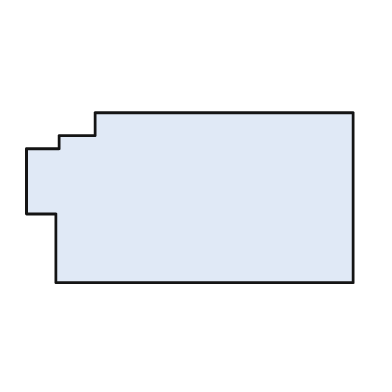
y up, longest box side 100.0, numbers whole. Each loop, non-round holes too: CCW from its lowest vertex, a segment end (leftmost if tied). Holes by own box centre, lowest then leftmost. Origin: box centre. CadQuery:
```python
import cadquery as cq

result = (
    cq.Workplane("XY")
    .moveTo(-41.0, -26.0)
    .lineTo(50.0, -26.0)
    .lineTo(50.0, 26.0)
    .lineTo(-29.0, 26.0)
    .lineTo(-29.0, 19.0)
    .lineTo(-40.0, 19.0)
    .lineTo(-40.0, 15.0)
    .lineTo(-50.0, 15.0)
    .lineTo(-50.0, -5.0)
    .lineTo(-41.0, -5.0)
    .close()
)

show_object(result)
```